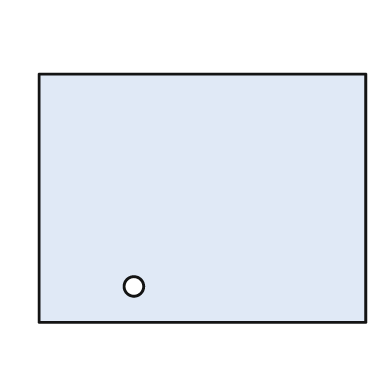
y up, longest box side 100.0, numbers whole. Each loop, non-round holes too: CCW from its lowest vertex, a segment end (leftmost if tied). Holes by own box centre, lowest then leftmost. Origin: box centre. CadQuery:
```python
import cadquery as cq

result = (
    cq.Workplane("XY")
    .moveTo(-50.0, -38.0)
    .lineTo(50.0, -38.0)
    .lineTo(50.0, 38.0)
    .lineTo(-50.0, 38.0)
    .close()
    .moveTo(-21.0, -27.0)
    .circle(3.0)
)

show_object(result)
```